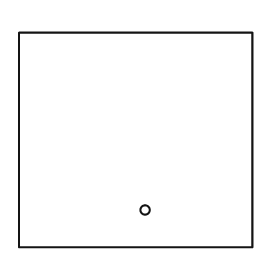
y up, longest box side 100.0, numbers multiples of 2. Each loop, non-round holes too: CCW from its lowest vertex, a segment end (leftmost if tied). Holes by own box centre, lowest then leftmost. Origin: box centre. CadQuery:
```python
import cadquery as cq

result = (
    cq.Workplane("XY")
    .moveTo(-50.0, -46.0)
    .lineTo(50.0, -46.0)
    .lineTo(50.0, 46.0)
    .lineTo(-50.0, 46.0)
    .close()
    .moveTo(4.0, -30.0)
    .circle(2.0)
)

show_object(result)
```